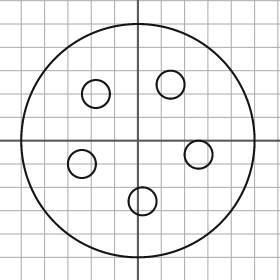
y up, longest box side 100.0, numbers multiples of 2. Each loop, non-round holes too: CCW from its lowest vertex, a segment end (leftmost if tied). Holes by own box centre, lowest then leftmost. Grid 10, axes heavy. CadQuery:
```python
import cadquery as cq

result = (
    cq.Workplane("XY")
    .moveTo(0.0, 0.0)
    .circle(50.0)
    .moveTo(2.0, -26.0)
    .circle(6.0)
    .moveTo(-24.0, -10.0)
    .circle(6.0)
    .moveTo(26.0, -6.0)
    .circle(6.0)
    .moveTo(-18.0, 20.0)
    .circle(6.0)
    .moveTo(14.0, 24.0)
    .circle(6.0)
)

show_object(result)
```